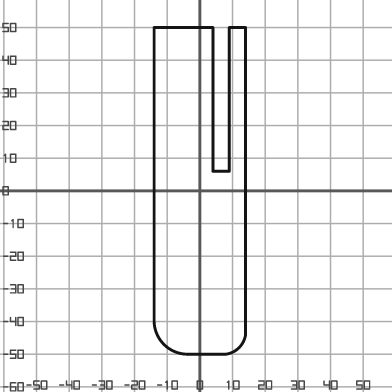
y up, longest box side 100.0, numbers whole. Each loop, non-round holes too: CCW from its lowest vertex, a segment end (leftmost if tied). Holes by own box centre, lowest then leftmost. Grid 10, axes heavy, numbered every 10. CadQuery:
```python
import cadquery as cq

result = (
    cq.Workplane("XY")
    .moveTo(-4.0, -50.0)
    .lineTo(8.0, -50.0)
    .threePointArc((12.0, -48.0), (14.0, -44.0))
    .lineTo(14.0, 50.0)
    .lineTo(9.0, 50.0)
    .lineTo(9.0, 6.0)
    .lineTo(4.0, 6.0)
    .lineTo(4.0, 50.0)
    .lineTo(-14.0, 50.0)
    .lineTo(-14.0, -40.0)
    .threePointArc((-11.0, -47.0), (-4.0, -50.0))
    .close()
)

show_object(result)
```